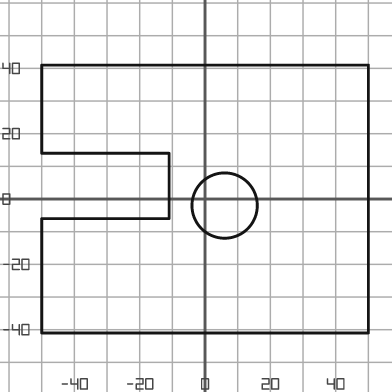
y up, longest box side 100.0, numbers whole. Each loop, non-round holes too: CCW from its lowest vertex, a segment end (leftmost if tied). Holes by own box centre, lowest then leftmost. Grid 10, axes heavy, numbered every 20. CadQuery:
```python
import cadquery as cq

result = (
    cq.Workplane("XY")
    .moveTo(-50.0, -41.0)
    .lineTo(50.0, -41.0)
    .lineTo(50.0, 41.0)
    .lineTo(-50.0, 41.0)
    .lineTo(-50.0, 14.0)
    .lineTo(-11.0, 14.0)
    .lineTo(-11.0, -6.0)
    .lineTo(-50.0, -6.0)
    .close()
    .moveTo(6.0, -2.0)
    .circle(10.0)
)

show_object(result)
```